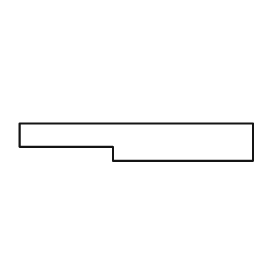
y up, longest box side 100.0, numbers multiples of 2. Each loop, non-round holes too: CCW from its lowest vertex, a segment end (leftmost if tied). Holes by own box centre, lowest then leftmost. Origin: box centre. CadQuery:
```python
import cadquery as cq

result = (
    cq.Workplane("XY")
    .moveTo(-10.0, -8.0)
    .lineTo(50.0, -8.0)
    .lineTo(50.0, 8.0)
    .lineTo(-50.0, 8.0)
    .lineTo(-50.0, -2.0)
    .lineTo(-10.0, -2.0)
    .close()
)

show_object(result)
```